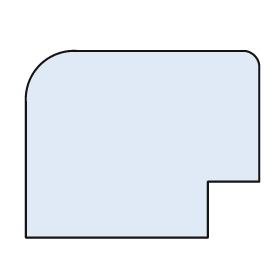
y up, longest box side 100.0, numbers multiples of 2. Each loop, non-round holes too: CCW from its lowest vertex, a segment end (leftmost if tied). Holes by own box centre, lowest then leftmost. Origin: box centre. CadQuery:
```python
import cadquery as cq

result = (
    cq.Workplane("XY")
    .moveTo(-50.0, -40.0)
    .lineTo(28.0, -40.0)
    .lineTo(28.0, -16.0)
    .lineTo(50.0, -16.0)
    .lineTo(50.0, 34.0)
    .threePointArc((48.0, 38.0), (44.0, 40.0))
    .lineTo(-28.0, 40.0)
    .threePointArc((-44.0, 34.0), (-50.0, 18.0))
    .close()
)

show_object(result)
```